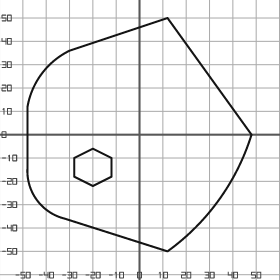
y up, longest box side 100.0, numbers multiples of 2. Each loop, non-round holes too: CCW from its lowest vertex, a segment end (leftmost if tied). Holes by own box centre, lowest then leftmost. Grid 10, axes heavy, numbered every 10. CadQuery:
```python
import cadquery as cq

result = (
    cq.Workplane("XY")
    .moveTo(12.0, -50.0)
    .threePointArc((34.0, -28.0), (48.0, 0.0))
    .lineTo(12.0, 50.0)
    .lineTo(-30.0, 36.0)
    .threePointArc((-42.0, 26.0), (-48.0, 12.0))
    .lineTo(-48.0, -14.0)
    .threePointArc((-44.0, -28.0), (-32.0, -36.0))
    .close()
    .moveTo(-20.0, -22.0)
    .lineTo(-12.0, -18.0)
    .lineTo(-12.0, -10.0)
    .lineTo(-20.0, -6.0)
    .lineTo(-28.0, -10.0)
    .lineTo(-28.0, -18.0)
    .close()
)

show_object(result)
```